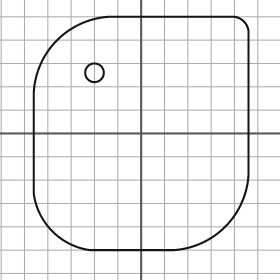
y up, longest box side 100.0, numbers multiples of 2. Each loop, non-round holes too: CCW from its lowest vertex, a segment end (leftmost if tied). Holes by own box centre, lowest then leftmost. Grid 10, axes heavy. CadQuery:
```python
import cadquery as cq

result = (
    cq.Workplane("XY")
    .moveTo(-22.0, -50.0)
    .lineTo(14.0, -50.0)
    .threePointArc((36.0, -40.0), (46.0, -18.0))
    .lineTo(46.0, 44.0)
    .threePointArc((44.0, 48.0), (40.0, 50.0))
    .lineTo(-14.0, 50.0)
    .threePointArc((-36.0, 40.0), (-46.0, 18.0))
    .lineTo(-46.0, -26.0)
    .threePointArc((-38.0, -42.0), (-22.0, -50.0))
    .close()
    .moveTo(-20.0, 26.0)
    .circle(4.0)
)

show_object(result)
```